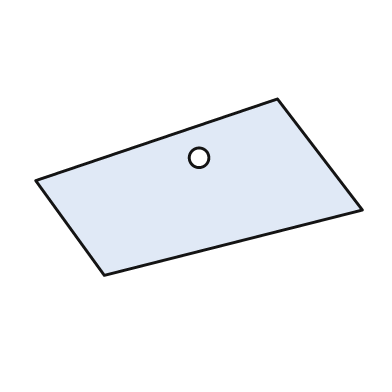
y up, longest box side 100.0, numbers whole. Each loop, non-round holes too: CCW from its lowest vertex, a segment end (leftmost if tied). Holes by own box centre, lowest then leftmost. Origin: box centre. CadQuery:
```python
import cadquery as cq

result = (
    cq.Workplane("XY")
    .moveTo(-29.0, -27.0)
    .lineTo(50.0, -7.0)
    .lineTo(24.0, 27.0)
    .lineTo(-50.0, 2.0)
    .close()
    .moveTo(0.0, 9.0)
    .circle(3.0)
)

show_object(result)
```